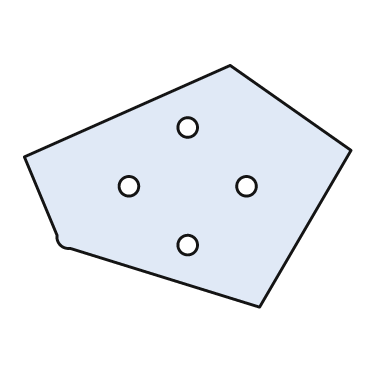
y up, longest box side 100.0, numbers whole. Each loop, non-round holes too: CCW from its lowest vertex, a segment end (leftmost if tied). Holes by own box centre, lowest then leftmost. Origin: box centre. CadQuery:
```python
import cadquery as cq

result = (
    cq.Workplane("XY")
    .moveTo(22.0, -37.0)
    .lineTo(50.0, 11.0)
    .lineTo(13.0, 37.0)
    .lineTo(-50.0, 9.0)
    .lineTo(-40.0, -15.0)
    .threePointArc((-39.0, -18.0), (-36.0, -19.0))
    .close()
    .moveTo(0.0, -18.0)
    .circle(3.0)
    .moveTo(-18.0, 0.0)
    .circle(3.0)
    .moveTo(18.0, 0.0)
    .circle(3.0)
    .moveTo(0.0, 18.0)
    .circle(3.0)
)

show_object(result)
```